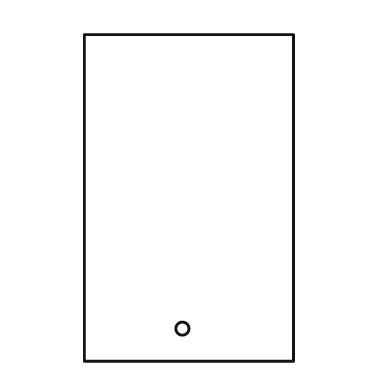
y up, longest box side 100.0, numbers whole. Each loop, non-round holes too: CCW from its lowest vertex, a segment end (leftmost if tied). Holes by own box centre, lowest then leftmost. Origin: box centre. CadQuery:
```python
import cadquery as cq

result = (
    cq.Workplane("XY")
    .moveTo(-32.0, -50.0)
    .lineTo(32.0, -50.0)
    .lineTo(32.0, 50.0)
    .lineTo(-32.0, 50.0)
    .close()
    .moveTo(-2.0, -40.0)
    .circle(2.0)
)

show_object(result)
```